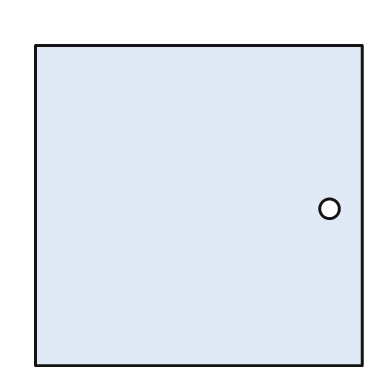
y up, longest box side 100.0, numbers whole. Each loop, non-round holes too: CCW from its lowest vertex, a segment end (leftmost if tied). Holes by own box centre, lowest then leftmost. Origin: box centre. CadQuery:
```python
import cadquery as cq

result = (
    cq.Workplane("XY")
    .moveTo(-50.0, -49.0)
    .lineTo(50.0, -49.0)
    .lineTo(50.0, 49.0)
    .lineTo(-50.0, 49.0)
    .close()
    .moveTo(40.0, -1.0)
    .circle(3.0)
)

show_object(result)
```